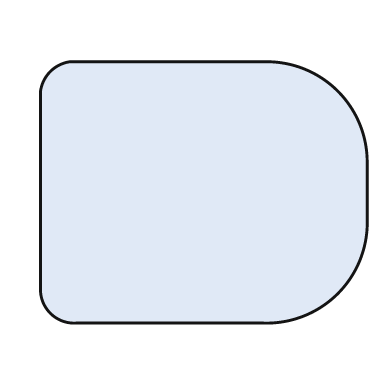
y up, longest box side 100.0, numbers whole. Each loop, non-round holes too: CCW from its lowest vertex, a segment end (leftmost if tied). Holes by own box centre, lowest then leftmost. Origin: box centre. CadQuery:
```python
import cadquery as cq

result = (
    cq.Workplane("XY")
    .moveTo(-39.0, -40.0)
    .lineTo(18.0, -40.0)
    .threePointArc((41.0, -31.0), (50.0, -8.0))
    .lineTo(50.0, 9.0)
    .threePointArc((41.0, 31.0), (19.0, 40.0))
    .lineTo(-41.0, 40.0)
    .threePointArc((-47.0, 37.0), (-50.0, 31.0))
    .lineTo(-50.0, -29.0)
    .threePointArc((-47.0, -37.0), (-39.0, -40.0))
    .close()
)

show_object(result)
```